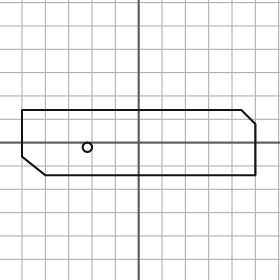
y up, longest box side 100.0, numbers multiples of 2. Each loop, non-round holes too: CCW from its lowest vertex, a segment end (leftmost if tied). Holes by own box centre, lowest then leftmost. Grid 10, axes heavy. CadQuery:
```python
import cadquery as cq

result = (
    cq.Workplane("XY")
    .moveTo(-40.0, -14.0)
    .lineTo(50.0, -14.0)
    .lineTo(50.0, 8.0)
    .lineTo(44.0, 14.0)
    .lineTo(-50.0, 14.0)
    .lineTo(-50.0, -6.0)
    .close()
    .moveTo(-22.0, -2.0)
    .circle(2.0)
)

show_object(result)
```